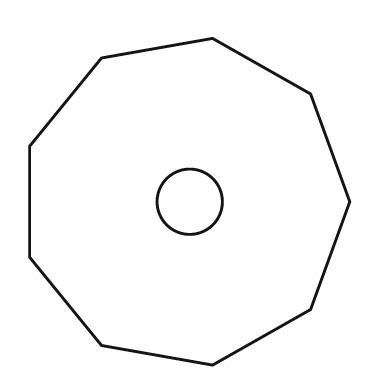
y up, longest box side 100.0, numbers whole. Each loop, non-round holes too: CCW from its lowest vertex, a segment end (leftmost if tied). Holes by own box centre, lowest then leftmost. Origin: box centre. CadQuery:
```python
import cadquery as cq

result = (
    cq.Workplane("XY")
    .moveTo(7.0, -50.0)
    .lineTo(37.0, -33.0)
    .lineTo(49.0, 0.0)
    .lineTo(37.0, 33.0)
    .lineTo(7.0, 50.0)
    .lineTo(-27.0, 44.0)
    .lineTo(-49.0, 17.0)
    .lineTo(-49.0, -17.0)
    .lineTo(-27.0, -44.0)
    .close()
    .moveTo(0.0, 0.0)
    .circle(10.0)
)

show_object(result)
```